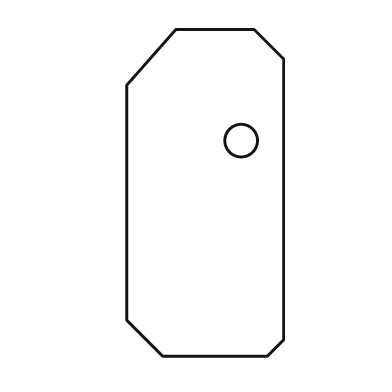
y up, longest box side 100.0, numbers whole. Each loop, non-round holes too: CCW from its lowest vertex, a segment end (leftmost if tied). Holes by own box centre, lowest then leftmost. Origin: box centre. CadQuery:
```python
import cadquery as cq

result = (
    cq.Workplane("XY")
    .moveTo(-13.0, -50.0)
    .lineTo(19.0, -50.0)
    .lineTo(24.0, -45.0)
    .lineTo(24.0, 41.0)
    .lineTo(15.0, 50.0)
    .lineTo(-9.0, 50.0)
    .lineTo(-24.0, 33.0)
    .lineTo(-24.0, -39.0)
    .close()
    .moveTo(11.0, 16.0)
    .circle(5.0)
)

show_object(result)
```